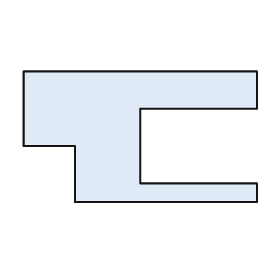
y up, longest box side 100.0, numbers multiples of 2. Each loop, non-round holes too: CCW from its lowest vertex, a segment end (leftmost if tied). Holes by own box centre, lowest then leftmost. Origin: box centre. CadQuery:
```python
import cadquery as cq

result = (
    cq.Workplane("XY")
    .moveTo(-28.0, -28.0)
    .lineTo(50.0, -28.0)
    .lineTo(50.0, -20.0)
    .lineTo(0.0, -20.0)
    .lineTo(0.0, 12.0)
    .lineTo(50.0, 12.0)
    .lineTo(50.0, 28.0)
    .lineTo(-50.0, 28.0)
    .lineTo(-50.0, -4.0)
    .lineTo(-28.0, -4.0)
    .close()
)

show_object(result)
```